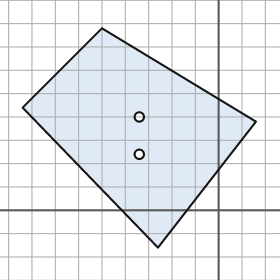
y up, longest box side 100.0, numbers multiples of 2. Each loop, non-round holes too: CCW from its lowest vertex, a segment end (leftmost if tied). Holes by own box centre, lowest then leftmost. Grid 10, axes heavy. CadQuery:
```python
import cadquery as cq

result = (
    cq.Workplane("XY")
    .moveTo(-26.0, -16.0)
    .lineTo(16.0, 38.0)
    .lineTo(-50.0, 78.0)
    .lineTo(-84.0, 44.0)
    .close()
    .moveTo(-34.0, 24.0)
    .circle(2.0)
    .moveTo(-34.0, 40.0)
    .circle(2.0)
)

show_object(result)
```